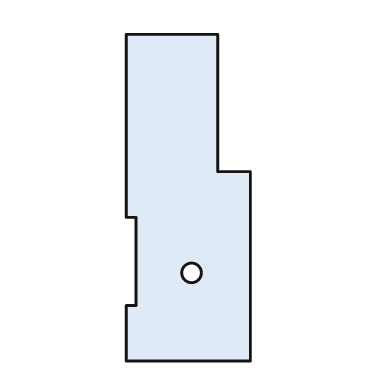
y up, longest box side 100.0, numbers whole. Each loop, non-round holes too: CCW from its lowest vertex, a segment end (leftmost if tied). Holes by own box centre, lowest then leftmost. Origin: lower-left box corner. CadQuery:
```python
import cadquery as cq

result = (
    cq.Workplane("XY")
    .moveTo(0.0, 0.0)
    .lineTo(38.0, 0.0)
    .lineTo(38.0, 58.0)
    .lineTo(28.0, 58.0)
    .lineTo(28.0, 100.0)
    .lineTo(0.0, 100.0)
    .lineTo(0.0, 44.0)
    .lineTo(3.0, 44.0)
    .lineTo(3.0, 17.0)
    .lineTo(0.0, 17.0)
    .close()
    .moveTo(20.0, 27.0)
    .circle(3.0)
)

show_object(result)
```